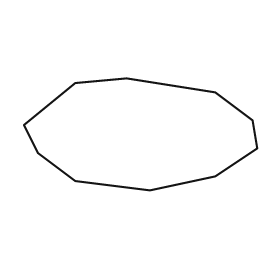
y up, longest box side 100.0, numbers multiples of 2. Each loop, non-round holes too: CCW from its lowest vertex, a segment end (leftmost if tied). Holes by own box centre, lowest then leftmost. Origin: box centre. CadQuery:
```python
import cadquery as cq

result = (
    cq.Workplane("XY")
    .moveTo(4.0, -24.0)
    .lineTo(32.0, -18.0)
    .lineTo(50.0, -6.0)
    .lineTo(48.0, 6.0)
    .lineTo(32.0, 18.0)
    .lineTo(-6.0, 24.0)
    .lineTo(-28.0, 22.0)
    .lineTo(-50.0, 4.0)
    .lineTo(-44.0, -8.0)
    .lineTo(-28.0, -20.0)
    .close()
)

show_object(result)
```